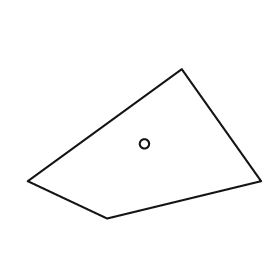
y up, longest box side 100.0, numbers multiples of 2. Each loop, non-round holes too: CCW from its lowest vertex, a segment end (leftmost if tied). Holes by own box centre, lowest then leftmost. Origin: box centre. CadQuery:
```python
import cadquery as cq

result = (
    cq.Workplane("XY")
    .moveTo(-16.0, -32.0)
    .lineTo(50.0, -16.0)
    .lineTo(16.0, 32.0)
    .lineTo(-50.0, -16.0)
    .close()
    .moveTo(0.0, 0.0)
    .circle(2.0)
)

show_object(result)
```